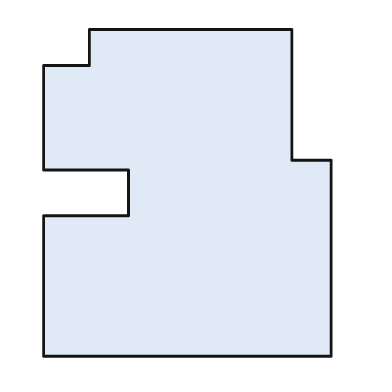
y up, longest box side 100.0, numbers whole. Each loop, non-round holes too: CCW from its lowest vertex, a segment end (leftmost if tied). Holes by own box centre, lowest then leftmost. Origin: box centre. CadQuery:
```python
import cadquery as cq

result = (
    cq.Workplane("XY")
    .moveTo(-44.0, -50.0)
    .lineTo(44.0, -50.0)
    .lineTo(44.0, 10.0)
    .lineTo(32.0, 10.0)
    .lineTo(32.0, 50.0)
    .lineTo(-30.0, 50.0)
    .lineTo(-30.0, 39.0)
    .lineTo(-44.0, 39.0)
    .lineTo(-44.0, 7.0)
    .lineTo(-18.0, 7.0)
    .lineTo(-18.0, -7.0)
    .lineTo(-44.0, -7.0)
    .close()
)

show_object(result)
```